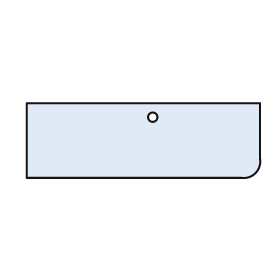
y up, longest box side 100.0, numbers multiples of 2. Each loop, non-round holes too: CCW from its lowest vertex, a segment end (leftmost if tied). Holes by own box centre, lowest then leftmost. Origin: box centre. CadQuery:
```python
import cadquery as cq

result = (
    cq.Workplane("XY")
    .moveTo(-50.0, -16.0)
    .lineTo(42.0, -16.0)
    .threePointArc((48.0, -14.0), (50.0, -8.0))
    .lineTo(50.0, 16.0)
    .lineTo(-50.0, 16.0)
    .close()
    .moveTo(4.0, 10.0)
    .circle(2.0)
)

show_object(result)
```